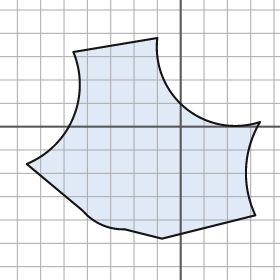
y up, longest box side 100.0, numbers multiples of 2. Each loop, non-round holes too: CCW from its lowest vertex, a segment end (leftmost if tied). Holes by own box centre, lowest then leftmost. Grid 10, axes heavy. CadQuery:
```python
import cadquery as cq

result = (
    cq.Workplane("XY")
    .moveTo(-8.0, -48.0)
    .lineTo(32.0, -38.0)
    .threePointArc((28.0, -18.0), (34.0, 2.0))
    .threePointArc((2.0, 8.0), (-10.0, 38.0))
    .lineTo(-46.0, 32.0)
    .threePointArc((-46.0, 4.0), (-66.0, -16.0))
    .lineTo(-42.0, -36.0)
    .threePointArc((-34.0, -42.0), (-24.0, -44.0))
    .close()
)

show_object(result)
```